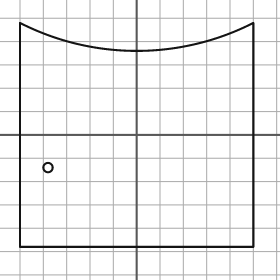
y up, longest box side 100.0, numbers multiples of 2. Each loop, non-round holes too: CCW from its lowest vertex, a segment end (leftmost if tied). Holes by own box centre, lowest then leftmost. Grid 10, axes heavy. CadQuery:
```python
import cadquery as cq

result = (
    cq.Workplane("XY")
    .moveTo(-50.0, -48.0)
    .lineTo(50.0, -48.0)
    .lineTo(50.0, 48.0)
    .threePointArc((0.0, 36.0), (-50.0, 48.0))
    .close()
    .moveTo(-38.0, -14.0)
    .circle(2.0)
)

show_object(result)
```